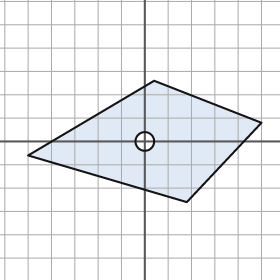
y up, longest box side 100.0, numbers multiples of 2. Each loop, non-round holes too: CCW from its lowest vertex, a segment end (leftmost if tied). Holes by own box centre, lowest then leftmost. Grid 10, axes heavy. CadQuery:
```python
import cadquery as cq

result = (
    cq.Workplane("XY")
    .moveTo(18.0, -26.0)
    .lineTo(50.0, 8.0)
    .lineTo(4.0, 26.0)
    .lineTo(-50.0, -6.0)
    .close()
    .moveTo(0.0, 0.0)
    .circle(4.0)
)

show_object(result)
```